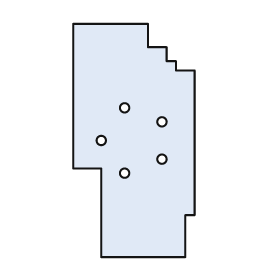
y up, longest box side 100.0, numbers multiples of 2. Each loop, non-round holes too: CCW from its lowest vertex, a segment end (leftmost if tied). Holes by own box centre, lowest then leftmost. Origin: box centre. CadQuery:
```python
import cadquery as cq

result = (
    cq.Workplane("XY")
    .moveTo(-14.0, -50.0)
    .lineTo(22.0, -50.0)
    .lineTo(22.0, -32.0)
    .lineTo(26.0, -32.0)
    .lineTo(26.0, 30.0)
    .lineTo(18.0, 30.0)
    .lineTo(18.0, 34.0)
    .lineTo(14.0, 34.0)
    .lineTo(14.0, 40.0)
    .lineTo(6.0, 40.0)
    .lineTo(6.0, 50.0)
    .lineTo(-26.0, 50.0)
    .lineTo(-26.0, -12.0)
    .lineTo(-14.0, -12.0)
    .close()
    .moveTo(-4.0, -14.0)
    .circle(2.0)
    .moveTo(12.0, -8.0)
    .circle(2.0)
    .moveTo(-14.0, 0.0)
    .circle(2.0)
    .moveTo(12.0, 8.0)
    .circle(2.0)
    .moveTo(-4.0, 14.0)
    .circle(2.0)
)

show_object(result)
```